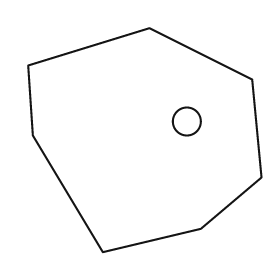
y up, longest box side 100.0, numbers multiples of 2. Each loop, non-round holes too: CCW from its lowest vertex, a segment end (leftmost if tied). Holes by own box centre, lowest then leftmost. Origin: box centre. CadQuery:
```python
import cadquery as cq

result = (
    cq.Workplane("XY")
    .moveTo(-18.0, -48.0)
    .lineTo(24.0, -38.0)
    .lineTo(50.0, -16.0)
    .lineTo(46.0, 26.0)
    .lineTo(2.0, 48.0)
    .lineTo(-50.0, 32.0)
    .lineTo(-48.0, 2.0)
    .close()
    .moveTo(18.0, 8.0)
    .circle(6.0)
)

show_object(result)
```